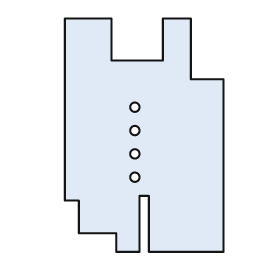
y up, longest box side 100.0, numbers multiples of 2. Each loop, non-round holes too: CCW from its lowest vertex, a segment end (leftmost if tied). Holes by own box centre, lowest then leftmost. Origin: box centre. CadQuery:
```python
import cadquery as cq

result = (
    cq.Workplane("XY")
    .moveTo(-12.0, -50.0)
    .lineTo(-2.0, -50.0)
    .lineTo(-2.0, -26.0)
    .lineTo(2.0, -26.0)
    .lineTo(2.0, -50.0)
    .lineTo(34.0, -50.0)
    .lineTo(34.0, 24.0)
    .lineTo(20.0, 24.0)
    .lineTo(20.0, 50.0)
    .lineTo(8.0, 50.0)
    .lineTo(8.0, 32.0)
    .lineTo(-14.0, 32.0)
    .lineTo(-14.0, 50.0)
    .lineTo(-34.0, 50.0)
    .lineTo(-34.0, -28.0)
    .lineTo(-28.0, -28.0)
    .lineTo(-28.0, -42.0)
    .lineTo(-12.0, -42.0)
    .close()
    .moveTo(-4.0, -18.0)
    .circle(2.0)
    .moveTo(-4.0, -8.0)
    .circle(2.0)
    .moveTo(-4.0, 2.0)
    .circle(2.0)
    .moveTo(-4.0, 12.0)
    .circle(2.0)
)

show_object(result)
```